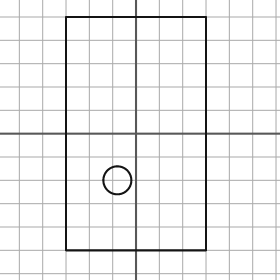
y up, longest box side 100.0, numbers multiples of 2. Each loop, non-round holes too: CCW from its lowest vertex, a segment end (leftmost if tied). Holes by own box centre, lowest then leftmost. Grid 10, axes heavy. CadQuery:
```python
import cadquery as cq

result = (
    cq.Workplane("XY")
    .moveTo(-30.0, -50.0)
    .lineTo(30.0, -50.0)
    .lineTo(30.0, 50.0)
    .lineTo(-30.0, 50.0)
    .close()
    .moveTo(-8.0, -20.0)
    .circle(6.0)
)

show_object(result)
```